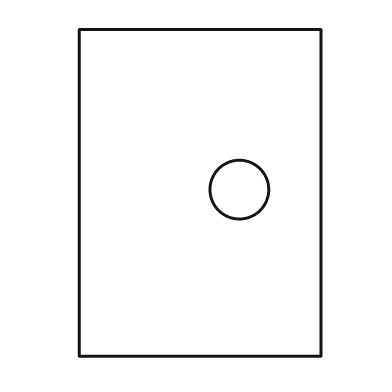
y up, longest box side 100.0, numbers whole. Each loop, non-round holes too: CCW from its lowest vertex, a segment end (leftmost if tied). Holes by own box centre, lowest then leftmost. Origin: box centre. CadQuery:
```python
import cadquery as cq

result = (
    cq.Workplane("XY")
    .moveTo(-37.0, -50.0)
    .lineTo(37.0, -50.0)
    .lineTo(37.0, 50.0)
    .lineTo(-37.0, 50.0)
    .close()
    .moveTo(12.0, 1.0)
    .circle(9.0)
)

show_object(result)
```